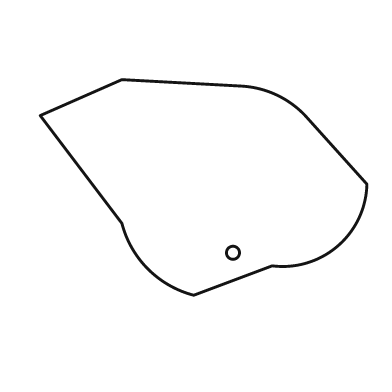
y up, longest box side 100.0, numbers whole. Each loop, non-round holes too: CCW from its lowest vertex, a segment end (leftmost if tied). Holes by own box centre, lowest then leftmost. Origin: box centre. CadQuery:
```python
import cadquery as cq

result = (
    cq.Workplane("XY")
    .moveTo(-3.0, -33.0)
    .lineTo(21.0, -24.0)
    .threePointArc((41.0, -18.0), (50.0, 1.0))
    .lineTo(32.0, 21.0)
    .threePointArc((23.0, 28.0), (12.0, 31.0))
    .lineTo(-25.0, 33.0)
    .lineTo(-50.0, 22.0)
    .lineTo(-25.0, -11.0)
    .threePointArc((-17.0, -25.0), (-3.0, -33.0))
    .close()
    .moveTo(9.0, -20.0)
    .circle(2.0)
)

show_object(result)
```